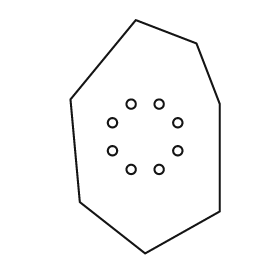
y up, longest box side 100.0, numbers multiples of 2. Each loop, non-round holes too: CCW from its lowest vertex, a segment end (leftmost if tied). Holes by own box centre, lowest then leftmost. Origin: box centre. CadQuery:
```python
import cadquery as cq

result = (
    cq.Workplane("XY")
    .moveTo(0.0, -50.0)
    .lineTo(32.0, -32.0)
    .lineTo(32.0, 14.0)
    .lineTo(22.0, 40.0)
    .lineTo(-4.0, 50.0)
    .lineTo(-32.0, 16.0)
    .lineTo(-28.0, -28.0)
    .close()
    .moveTo(-6.0, -14.0)
    .circle(2.0)
    .moveTo(6.0, -14.0)
    .circle(2.0)
    .moveTo(-14.0, -6.0)
    .circle(2.0)
    .moveTo(14.0, -6.0)
    .circle(2.0)
    .moveTo(-14.0, 6.0)
    .circle(2.0)
    .moveTo(14.0, 6.0)
    .circle(2.0)
    .moveTo(-6.0, 14.0)
    .circle(2.0)
    .moveTo(6.0, 14.0)
    .circle(2.0)
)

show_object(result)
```